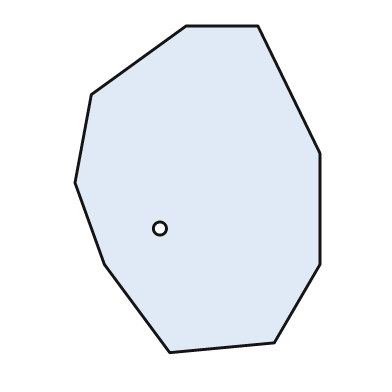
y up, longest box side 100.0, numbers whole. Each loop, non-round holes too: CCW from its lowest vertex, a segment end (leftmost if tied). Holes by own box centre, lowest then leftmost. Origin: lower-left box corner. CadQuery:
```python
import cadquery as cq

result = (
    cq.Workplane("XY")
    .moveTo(29.0, 0.0)
    .lineTo(61.0, 3.0)
    .lineTo(75.0, 27.0)
    .lineTo(75.0, 61.0)
    .lineTo(56.0, 100.0)
    .lineTo(34.0, 100.0)
    .lineTo(5.0, 79.0)
    .lineTo(0.0, 52.0)
    .lineTo(9.0, 27.0)
    .close()
    .moveTo(26.0, 38.0)
    .circle(2.0)
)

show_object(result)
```